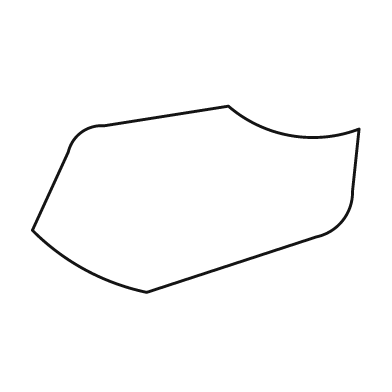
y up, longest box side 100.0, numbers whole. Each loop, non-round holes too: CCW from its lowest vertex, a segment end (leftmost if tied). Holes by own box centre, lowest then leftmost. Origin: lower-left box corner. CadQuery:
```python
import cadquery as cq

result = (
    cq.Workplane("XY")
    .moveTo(35.0, 0.0)
    .lineTo(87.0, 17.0)
    .threePointArc((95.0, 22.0), (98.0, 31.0))
    .lineTo(100.0, 50.0)
    .threePointArc((79.0, 48.0), (60.0, 57.0))
    .lineTo(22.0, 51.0)
    .threePointArc((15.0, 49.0), (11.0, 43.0))
    .lineTo(0.0, 19.0)
    .threePointArc((16.0, 7.0), (35.0, 0.0))
    .close()
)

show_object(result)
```